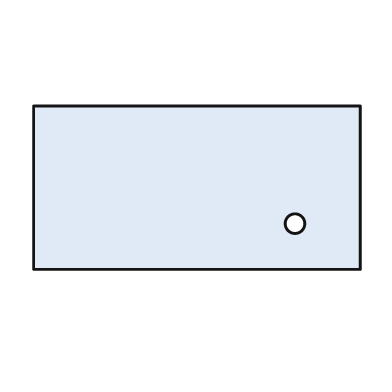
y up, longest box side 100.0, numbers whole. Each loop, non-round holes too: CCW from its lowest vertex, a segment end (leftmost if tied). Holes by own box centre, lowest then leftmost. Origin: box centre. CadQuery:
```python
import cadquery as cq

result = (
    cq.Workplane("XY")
    .moveTo(-50.0, -25.0)
    .lineTo(50.0, -25.0)
    .lineTo(50.0, 25.0)
    .lineTo(-50.0, 25.0)
    .close()
    .moveTo(30.0, -11.0)
    .circle(3.0)
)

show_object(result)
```